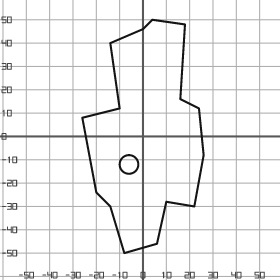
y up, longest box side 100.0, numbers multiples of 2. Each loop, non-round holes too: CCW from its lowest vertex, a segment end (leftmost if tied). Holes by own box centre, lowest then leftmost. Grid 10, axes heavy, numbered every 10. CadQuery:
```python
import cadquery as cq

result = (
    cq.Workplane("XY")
    .moveTo(-8.0, -50.0)
    .lineTo(6.0, -46.0)
    .lineTo(10.0, -28.0)
    .lineTo(22.0, -30.0)
    .lineTo(26.0, -8.0)
    .lineTo(24.0, 12.0)
    .lineTo(16.0, 16.0)
    .lineTo(18.0, 48.0)
    .lineTo(4.0, 50.0)
    .lineTo(0.0, 46.0)
    .lineTo(-14.0, 40.0)
    .lineTo(-10.0, 12.0)
    .lineTo(-26.0, 8.0)
    .lineTo(-20.0, -24.0)
    .lineTo(-14.0, -30.0)
    .close()
    .moveTo(-6.0, -12.0)
    .circle(4.0)
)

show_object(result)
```